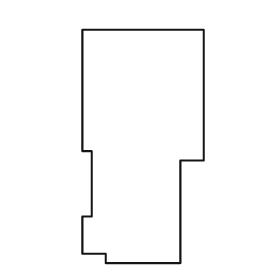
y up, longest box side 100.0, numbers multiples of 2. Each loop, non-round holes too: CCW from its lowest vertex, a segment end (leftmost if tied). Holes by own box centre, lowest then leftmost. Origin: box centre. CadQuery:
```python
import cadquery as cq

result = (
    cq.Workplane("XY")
    .moveTo(-16.0, -50.0)
    .lineTo(16.0, -50.0)
    .lineTo(16.0, -6.0)
    .lineTo(26.0, -6.0)
    .lineTo(26.0, 50.0)
    .lineTo(-26.0, 50.0)
    .lineTo(-26.0, -2.0)
    .lineTo(-22.0, -2.0)
    .lineTo(-22.0, -30.0)
    .lineTo(-26.0, -30.0)
    .lineTo(-26.0, -46.0)
    .lineTo(-16.0, -46.0)
    .close()
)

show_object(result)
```